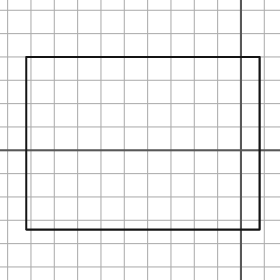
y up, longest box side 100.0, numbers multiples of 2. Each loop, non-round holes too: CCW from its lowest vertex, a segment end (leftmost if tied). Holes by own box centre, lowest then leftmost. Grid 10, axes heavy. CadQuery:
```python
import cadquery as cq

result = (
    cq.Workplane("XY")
    .moveTo(-92.0, -34.0)
    .lineTo(8.0, -34.0)
    .lineTo(8.0, 40.0)
    .lineTo(-92.0, 40.0)
    .close()
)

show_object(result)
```